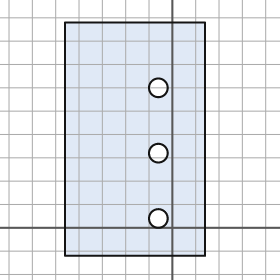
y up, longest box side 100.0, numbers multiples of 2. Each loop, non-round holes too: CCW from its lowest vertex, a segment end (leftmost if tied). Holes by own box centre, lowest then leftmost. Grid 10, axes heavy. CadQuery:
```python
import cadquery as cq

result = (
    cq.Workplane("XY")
    .moveTo(-46.0, -12.0)
    .lineTo(14.0, -12.0)
    .lineTo(14.0, 88.0)
    .lineTo(-46.0, 88.0)
    .close()
    .moveTo(-6.0, 4.0)
    .circle(4.0)
    .moveTo(-6.0, 32.0)
    .circle(4.0)
    .moveTo(-6.0, 60.0)
    .circle(4.0)
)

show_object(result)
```